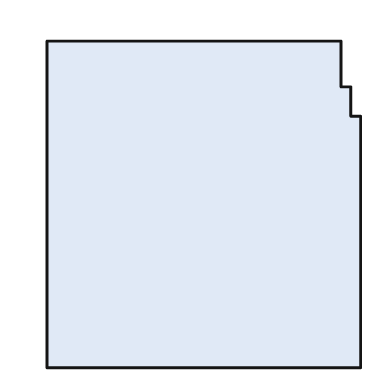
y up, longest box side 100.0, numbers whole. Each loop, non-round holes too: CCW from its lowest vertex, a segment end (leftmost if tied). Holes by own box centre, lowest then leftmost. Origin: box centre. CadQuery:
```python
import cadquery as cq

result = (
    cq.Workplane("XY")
    .moveTo(-48.0, -50.0)
    .lineTo(48.0, -50.0)
    .lineTo(48.0, 27.0)
    .lineTo(45.0, 27.0)
    .lineTo(45.0, 36.0)
    .lineTo(42.0, 36.0)
    .lineTo(42.0, 50.0)
    .lineTo(-48.0, 50.0)
    .close()
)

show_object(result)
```